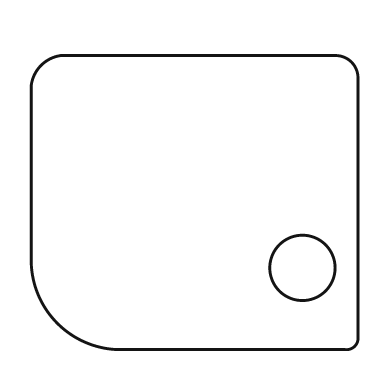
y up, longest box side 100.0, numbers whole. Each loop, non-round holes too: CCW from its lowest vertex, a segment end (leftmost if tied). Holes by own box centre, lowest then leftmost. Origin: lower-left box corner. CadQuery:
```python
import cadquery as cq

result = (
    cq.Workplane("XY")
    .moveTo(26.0, 0.0)
    .lineTo(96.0, 0.0)
    .threePointArc((99.0, 1.0), (100.0, 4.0))
    .lineTo(100.0, 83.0)
    .threePointArc((98.0, 88.0), (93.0, 90.0))
    .lineTo(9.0, 90.0)
    .threePointArc((3.0, 87.0), (0.0, 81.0))
    .lineTo(0.0, 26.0)
    .threePointArc((8.0, 8.0), (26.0, 0.0))
    .close()
    .moveTo(83.0, 25.0)
    .circle(10.0)
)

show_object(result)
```